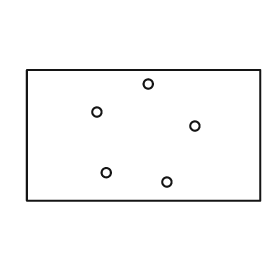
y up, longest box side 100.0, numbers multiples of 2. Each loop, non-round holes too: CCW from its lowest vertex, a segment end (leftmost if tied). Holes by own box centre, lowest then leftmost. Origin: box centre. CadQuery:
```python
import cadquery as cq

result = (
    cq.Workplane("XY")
    .moveTo(-50.0, -28.0)
    .lineTo(50.0, -28.0)
    .lineTo(50.0, 28.0)
    .lineTo(-50.0, 28.0)
    .close()
    .moveTo(10.0, -20.0)
    .circle(2.0)
    .moveTo(-16.0, -16.0)
    .circle(2.0)
    .moveTo(22.0, 4.0)
    .circle(2.0)
    .moveTo(-20.0, 10.0)
    .circle(2.0)
    .moveTo(2.0, 22.0)
    .circle(2.0)
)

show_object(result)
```